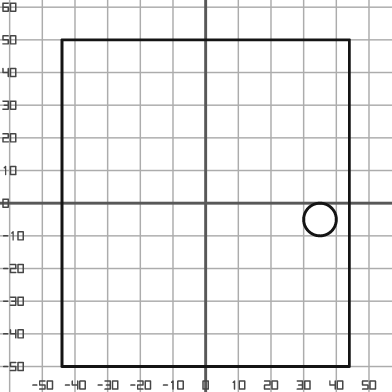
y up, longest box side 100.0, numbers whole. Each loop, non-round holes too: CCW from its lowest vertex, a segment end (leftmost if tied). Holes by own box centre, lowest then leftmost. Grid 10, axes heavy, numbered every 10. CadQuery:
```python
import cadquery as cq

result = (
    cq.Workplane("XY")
    .moveTo(-44.0, -50.0)
    .lineTo(44.0, -50.0)
    .lineTo(44.0, 50.0)
    .lineTo(-44.0, 50.0)
    .close()
    .moveTo(35.0, -5.0)
    .circle(5.0)
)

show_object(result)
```